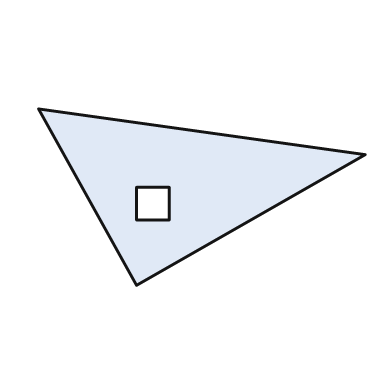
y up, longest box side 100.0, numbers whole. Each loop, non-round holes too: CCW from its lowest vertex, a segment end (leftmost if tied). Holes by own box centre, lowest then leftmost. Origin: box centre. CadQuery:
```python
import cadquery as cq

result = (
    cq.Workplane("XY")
    .moveTo(-20.0, -27.0)
    .lineTo(50.0, 13.0)
    .lineTo(-50.0, 27.0)
    .close()
    .moveTo(-20.0, -7.0)
    .lineTo(-10.0, -7.0)
    .lineTo(-10.0, 3.0)
    .lineTo(-20.0, 3.0)
    .close()
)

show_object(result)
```